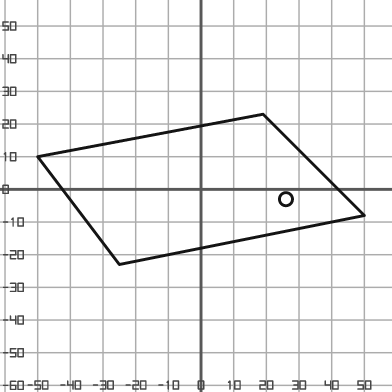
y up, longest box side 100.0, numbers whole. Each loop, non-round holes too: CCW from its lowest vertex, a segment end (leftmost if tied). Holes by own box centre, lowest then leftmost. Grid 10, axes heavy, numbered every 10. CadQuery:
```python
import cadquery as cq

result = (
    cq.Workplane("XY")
    .moveTo(-25.0, -23.0)
    .lineTo(50.0, -8.0)
    .lineTo(19.0, 23.0)
    .lineTo(-50.0, 10.0)
    .close()
    .moveTo(26.0, -3.0)
    .circle(2.0)
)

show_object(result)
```